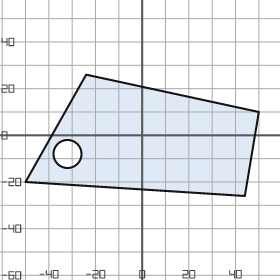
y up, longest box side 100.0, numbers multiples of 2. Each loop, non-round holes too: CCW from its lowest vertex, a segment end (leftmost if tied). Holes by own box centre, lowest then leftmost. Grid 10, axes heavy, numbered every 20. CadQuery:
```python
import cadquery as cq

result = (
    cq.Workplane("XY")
    .moveTo(44.0, -26.0)
    .lineTo(50.0, 10.0)
    .lineTo(-24.0, 26.0)
    .lineTo(-50.0, -20.0)
    .close()
    .moveTo(-32.0, -8.0)
    .circle(6.0)
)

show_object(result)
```